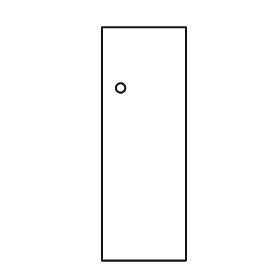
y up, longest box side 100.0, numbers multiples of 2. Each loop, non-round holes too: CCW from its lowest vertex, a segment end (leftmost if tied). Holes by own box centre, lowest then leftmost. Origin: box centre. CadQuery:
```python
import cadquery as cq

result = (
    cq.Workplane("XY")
    .moveTo(-18.0, -50.0)
    .lineTo(18.0, -50.0)
    .lineTo(18.0, 50.0)
    .lineTo(-18.0, 50.0)
    .close()
    .moveTo(-10.0, 24.0)
    .circle(2.0)
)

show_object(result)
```